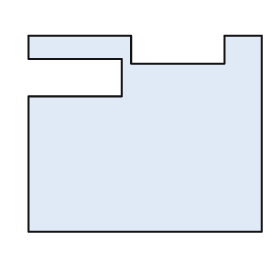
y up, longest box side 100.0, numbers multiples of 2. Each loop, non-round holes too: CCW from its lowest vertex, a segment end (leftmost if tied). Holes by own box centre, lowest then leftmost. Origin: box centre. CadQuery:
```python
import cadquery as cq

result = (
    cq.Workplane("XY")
    .moveTo(-50.0, -42.0)
    .lineTo(50.0, -42.0)
    .lineTo(50.0, 42.0)
    .lineTo(34.0, 42.0)
    .lineTo(34.0, 30.0)
    .lineTo(-6.0, 30.0)
    .lineTo(-6.0, 42.0)
    .lineTo(-50.0, 42.0)
    .lineTo(-50.0, 32.0)
    .lineTo(-10.0, 32.0)
    .lineTo(-10.0, 16.0)
    .lineTo(-50.0, 16.0)
    .close()
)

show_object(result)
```